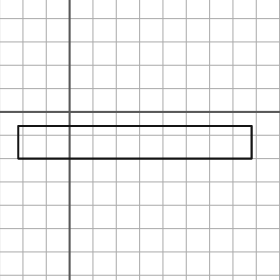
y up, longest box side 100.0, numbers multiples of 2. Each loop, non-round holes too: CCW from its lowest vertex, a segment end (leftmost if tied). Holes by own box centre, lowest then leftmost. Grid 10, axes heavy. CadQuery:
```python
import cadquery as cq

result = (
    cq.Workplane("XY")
    .moveTo(-22.0, -20.0)
    .lineTo(78.0, -20.0)
    .lineTo(78.0, -6.0)
    .lineTo(-22.0, -6.0)
    .close()
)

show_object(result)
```